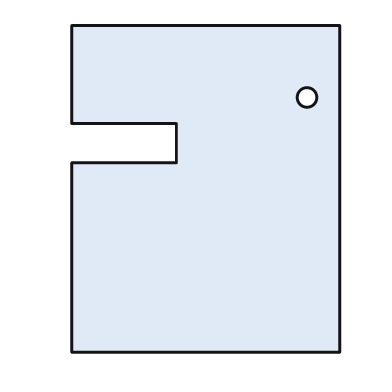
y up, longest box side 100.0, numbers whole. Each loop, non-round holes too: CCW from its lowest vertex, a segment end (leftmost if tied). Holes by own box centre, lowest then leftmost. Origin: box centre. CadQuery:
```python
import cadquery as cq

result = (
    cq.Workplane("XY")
    .moveTo(-41.0, -50.0)
    .lineTo(41.0, -50.0)
    .lineTo(41.0, 50.0)
    .lineTo(-41.0, 50.0)
    .lineTo(-41.0, 20.0)
    .lineTo(-9.0, 20.0)
    .lineTo(-9.0, 8.0)
    .lineTo(-41.0, 8.0)
    .close()
    .moveTo(31.0, 28.0)
    .circle(3.0)
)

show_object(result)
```